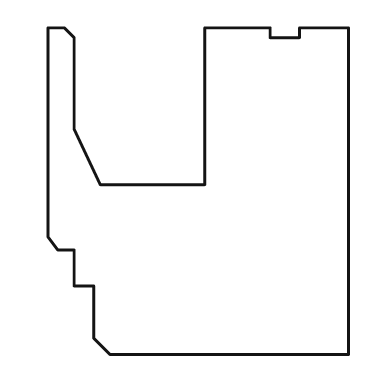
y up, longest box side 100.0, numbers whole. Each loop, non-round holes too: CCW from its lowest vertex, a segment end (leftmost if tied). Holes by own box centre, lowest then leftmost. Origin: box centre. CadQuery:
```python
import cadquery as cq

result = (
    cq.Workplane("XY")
    .moveTo(-27.0, -50.0)
    .lineTo(46.0, -50.0)
    .lineTo(46.0, 50.0)
    .lineTo(31.0, 50.0)
    .lineTo(31.0, 47.0)
    .lineTo(22.0, 47.0)
    .lineTo(22.0, 50.0)
    .lineTo(2.0, 50.0)
    .lineTo(2.0, 2.0)
    .lineTo(-30.0, 2.0)
    .lineTo(-38.0, 19.0)
    .lineTo(-38.0, 47.0)
    .lineTo(-41.0, 50.0)
    .lineTo(-46.0, 50.0)
    .lineTo(-46.0, -14.0)
    .lineTo(-43.0, -18.0)
    .lineTo(-38.0, -18.0)
    .lineTo(-38.0, -29.0)
    .lineTo(-32.0, -29.0)
    .lineTo(-32.0, -45.0)
    .close()
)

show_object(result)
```